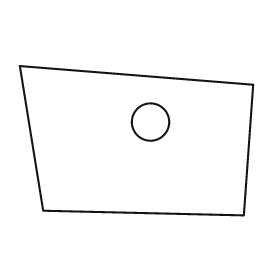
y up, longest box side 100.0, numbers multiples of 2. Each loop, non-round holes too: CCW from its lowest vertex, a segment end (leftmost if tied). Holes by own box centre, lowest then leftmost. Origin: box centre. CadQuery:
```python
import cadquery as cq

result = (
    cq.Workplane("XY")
    .moveTo(46.0, -32.0)
    .lineTo(50.0, 24.0)
    .lineTo(-50.0, 32.0)
    .lineTo(-40.0, -30.0)
    .close()
    .moveTo(6.0, 8.0)
    .circle(8.0)
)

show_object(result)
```